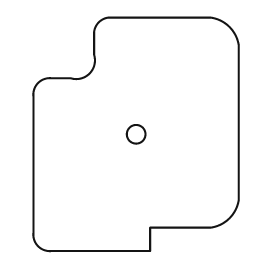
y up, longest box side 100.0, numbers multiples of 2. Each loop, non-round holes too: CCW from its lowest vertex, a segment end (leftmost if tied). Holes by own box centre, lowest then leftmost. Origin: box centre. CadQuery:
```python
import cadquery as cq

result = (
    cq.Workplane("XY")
    .moveTo(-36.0, -50.0)
    .lineTo(6.0, -50.0)
    .lineTo(6.0, -40.0)
    .lineTo(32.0, -40.0)
    .threePointArc((40.0, -36.0), (44.0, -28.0))
    .lineTo(44.0, 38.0)
    .threePointArc((40.0, 46.0), (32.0, 50.0))
    .lineTo(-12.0, 50.0)
    .threePointArc((-16.0, 48.0), (-18.0, 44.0))
    .lineTo(-18.0, 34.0)
    .threePointArc((-20.0, 26.0), (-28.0, 24.0))
    .lineTo(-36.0, 24.0)
    .threePointArc((-42.0, 22.0), (-44.0, 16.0))
    .lineTo(-44.0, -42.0)
    .threePointArc((-42.0, -48.0), (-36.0, -50.0))
    .close()
    .moveTo(0.0, 0.0)
    .circle(4.0)
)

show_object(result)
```